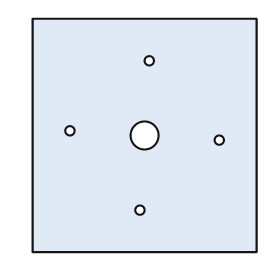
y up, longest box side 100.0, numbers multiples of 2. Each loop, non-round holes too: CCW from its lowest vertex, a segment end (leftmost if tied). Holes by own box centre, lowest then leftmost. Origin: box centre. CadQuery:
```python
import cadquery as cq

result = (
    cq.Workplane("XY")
    .moveTo(-48.0, -50.0)
    .lineTo(48.0, -50.0)
    .lineTo(48.0, 50.0)
    .lineTo(-48.0, 50.0)
    .close()
    .moveTo(-2.0, -32.0)
    .circle(2.0)
    .moveTo(32.0, -2.0)
    .circle(2.0)
    .moveTo(0.0, 0.0)
    .circle(6.0)
    .moveTo(-32.0, 2.0)
    .circle(2.0)
    .moveTo(2.0, 32.0)
    .circle(2.0)
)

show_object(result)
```